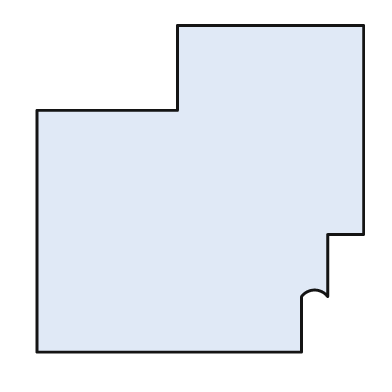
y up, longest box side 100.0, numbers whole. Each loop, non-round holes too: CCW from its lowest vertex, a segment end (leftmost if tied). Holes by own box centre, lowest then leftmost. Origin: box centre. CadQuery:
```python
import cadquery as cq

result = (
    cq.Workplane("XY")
    .moveTo(-50.0, -50.0)
    .lineTo(31.0, -50.0)
    .lineTo(31.0, -33.0)
    .threePointArc((35.0, -31.0), (39.0, -33.0))
    .lineTo(39.0, -14.0)
    .lineTo(50.0, -14.0)
    .lineTo(50.0, 50.0)
    .lineTo(-7.0, 50.0)
    .lineTo(-7.0, 24.0)
    .lineTo(-50.0, 24.0)
    .close()
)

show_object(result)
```